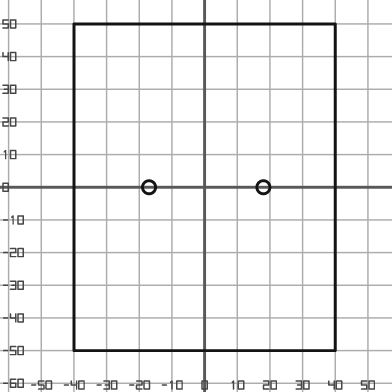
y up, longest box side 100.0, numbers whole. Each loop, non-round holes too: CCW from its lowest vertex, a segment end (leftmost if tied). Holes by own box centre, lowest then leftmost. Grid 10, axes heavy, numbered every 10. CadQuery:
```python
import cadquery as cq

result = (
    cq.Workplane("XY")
    .moveTo(-40.0, -50.0)
    .lineTo(40.0, -50.0)
    .lineTo(40.0, 50.0)
    .lineTo(-40.0, 50.0)
    .close()
    .moveTo(-17.0, 0.0)
    .circle(2.0)
    .moveTo(18.0, 0.0)
    .circle(2.0)
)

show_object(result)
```